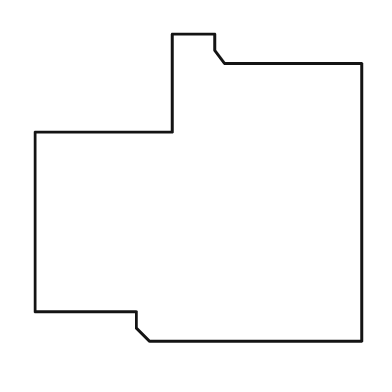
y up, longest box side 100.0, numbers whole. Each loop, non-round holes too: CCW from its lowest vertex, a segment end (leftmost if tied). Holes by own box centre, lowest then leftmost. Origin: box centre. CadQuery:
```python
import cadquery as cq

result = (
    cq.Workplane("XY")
    .moveTo(-15.0, -47.0)
    .lineTo(50.0, -47.0)
    .lineTo(50.0, 38.0)
    .lineTo(8.0, 38.0)
    .lineTo(5.0, 42.0)
    .lineTo(5.0, 47.0)
    .lineTo(-8.0, 47.0)
    .lineTo(-8.0, 17.0)
    .lineTo(-50.0, 17.0)
    .lineTo(-50.0, -38.0)
    .lineTo(-19.0, -38.0)
    .lineTo(-19.0, -43.0)
    .close()
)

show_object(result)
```